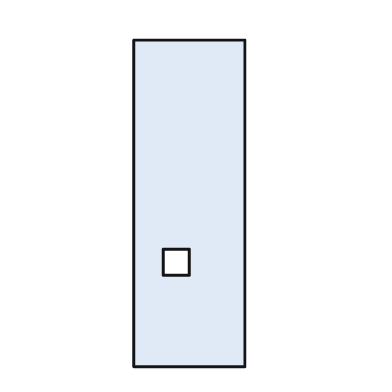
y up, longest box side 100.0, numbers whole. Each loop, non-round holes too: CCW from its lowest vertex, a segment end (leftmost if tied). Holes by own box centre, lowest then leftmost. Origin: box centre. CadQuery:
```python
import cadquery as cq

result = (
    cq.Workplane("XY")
    .moveTo(-17.0, -50.0)
    .lineTo(17.0, -50.0)
    .lineTo(17.0, 50.0)
    .lineTo(-17.0, 50.0)
    .close()
    .moveTo(-8.0, -22.0)
    .lineTo(0.0, -22.0)
    .lineTo(0.0, -14.0)
    .lineTo(-8.0, -14.0)
    .close()
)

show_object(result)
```